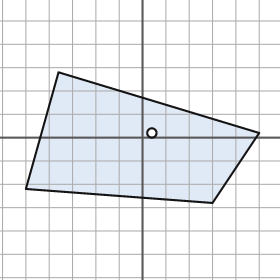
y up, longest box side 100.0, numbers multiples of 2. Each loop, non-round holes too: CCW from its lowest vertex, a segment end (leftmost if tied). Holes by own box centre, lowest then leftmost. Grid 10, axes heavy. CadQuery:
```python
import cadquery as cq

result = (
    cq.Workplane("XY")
    .moveTo(30.0, -28.0)
    .lineTo(50.0, 2.0)
    .lineTo(-36.0, 28.0)
    .lineTo(-50.0, -22.0)
    .close()
    .moveTo(4.0, 2.0)
    .circle(2.0)
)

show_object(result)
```